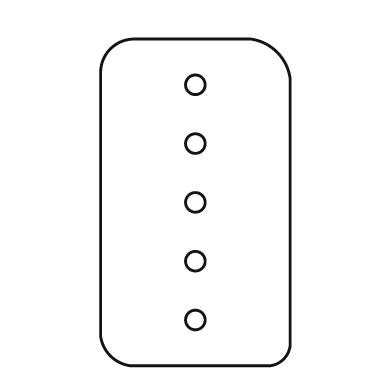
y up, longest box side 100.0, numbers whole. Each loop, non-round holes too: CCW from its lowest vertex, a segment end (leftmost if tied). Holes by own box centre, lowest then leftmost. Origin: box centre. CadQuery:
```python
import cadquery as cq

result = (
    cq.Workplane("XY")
    .moveTo(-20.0, -50.0)
    .lineTo(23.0, -50.0)
    .threePointArc((27.0, -48.0), (29.0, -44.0))
    .lineTo(29.0, 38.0)
    .threePointArc((25.0, 46.0), (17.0, 50.0))
    .lineTo(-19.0, 50.0)
    .threePointArc((-26.0, 47.0), (-29.0, 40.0))
    .lineTo(-29.0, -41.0)
    .threePointArc((-26.0, -47.0), (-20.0, -50.0))
    .close()
    .moveTo(0.0, -36.0)
    .circle(3.0)
    .moveTo(0.0, -18.0)
    .circle(3.0)
    .moveTo(0.0, 0.0)
    .circle(3.0)
    .moveTo(0.0, 18.0)
    .circle(3.0)
    .moveTo(0.0, 36.0)
    .circle(3.0)
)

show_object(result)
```